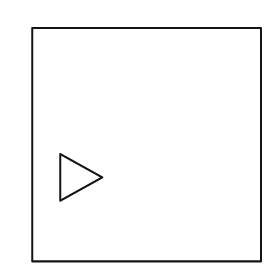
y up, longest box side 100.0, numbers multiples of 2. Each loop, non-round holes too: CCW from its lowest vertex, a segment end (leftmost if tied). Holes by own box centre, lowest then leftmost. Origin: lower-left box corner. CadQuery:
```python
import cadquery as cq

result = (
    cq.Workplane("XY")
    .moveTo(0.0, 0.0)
    .lineTo(98.0, 0.0)
    .lineTo(98.0, 100.0)
    .lineTo(0.0, 100.0)
    .close()
    .moveTo(12.0, 26.0)
    .lineTo(30.0, 36.0)
    .lineTo(12.0, 46.0)
    .close()
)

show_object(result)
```